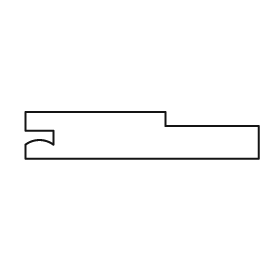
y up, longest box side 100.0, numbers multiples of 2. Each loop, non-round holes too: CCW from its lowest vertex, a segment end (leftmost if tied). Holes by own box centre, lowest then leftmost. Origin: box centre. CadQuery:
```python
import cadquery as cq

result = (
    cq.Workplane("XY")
    .moveTo(-50.0, -10.0)
    .lineTo(50.0, -10.0)
    .lineTo(50.0, 4.0)
    .lineTo(10.0, 4.0)
    .lineTo(10.0, 10.0)
    .lineTo(-50.0, 10.0)
    .lineTo(-50.0, 2.0)
    .lineTo(-38.0, 2.0)
    .lineTo(-38.0, -4.0)
    .threePointArc((-44.0, -2.0), (-50.0, -4.0))
    .close()
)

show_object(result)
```